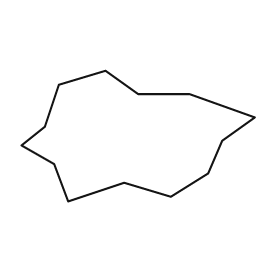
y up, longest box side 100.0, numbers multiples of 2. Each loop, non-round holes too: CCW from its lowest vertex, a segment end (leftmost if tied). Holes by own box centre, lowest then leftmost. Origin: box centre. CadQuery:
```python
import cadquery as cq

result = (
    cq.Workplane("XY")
    .moveTo(-30.0, -28.0)
    .lineTo(-6.0, -20.0)
    .lineTo(14.0, -26.0)
    .lineTo(30.0, -16.0)
    .lineTo(36.0, -2.0)
    .lineTo(50.0, 8.0)
    .lineTo(22.0, 18.0)
    .lineTo(0.0, 18.0)
    .lineTo(-14.0, 28.0)
    .lineTo(-34.0, 22.0)
    .lineTo(-40.0, 4.0)
    .lineTo(-50.0, -4.0)
    .lineTo(-36.0, -12.0)
    .close()
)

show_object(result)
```